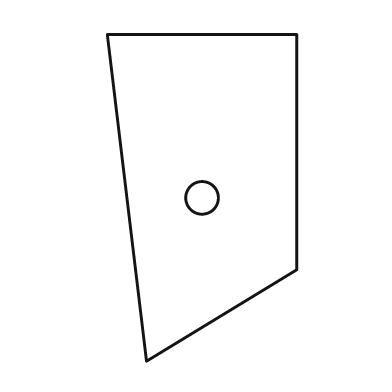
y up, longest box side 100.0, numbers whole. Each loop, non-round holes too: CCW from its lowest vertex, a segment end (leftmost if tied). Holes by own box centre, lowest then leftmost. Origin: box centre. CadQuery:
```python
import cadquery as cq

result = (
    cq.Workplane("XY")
    .moveTo(-17.0, -50.0)
    .lineTo(29.0, -22.0)
    .lineTo(29.0, 50.0)
    .lineTo(-29.0, 50.0)
    .close()
    .moveTo(0.0, 0.0)
    .circle(5.0)
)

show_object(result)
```